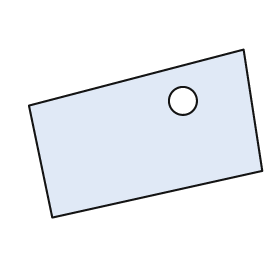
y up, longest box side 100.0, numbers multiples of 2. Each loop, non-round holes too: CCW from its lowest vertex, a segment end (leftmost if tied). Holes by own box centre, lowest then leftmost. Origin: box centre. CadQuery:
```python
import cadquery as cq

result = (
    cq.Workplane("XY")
    .moveTo(-40.0, -36.0)
    .lineTo(50.0, -16.0)
    .lineTo(42.0, 36.0)
    .lineTo(-50.0, 12.0)
    .close()
    .moveTo(16.0, 14.0)
    .circle(6.0)
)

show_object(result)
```